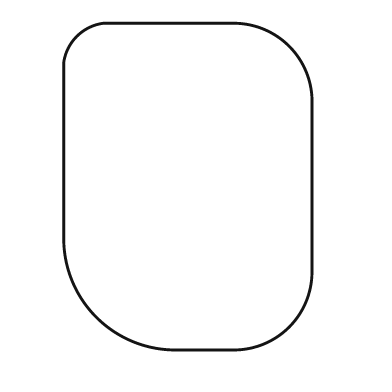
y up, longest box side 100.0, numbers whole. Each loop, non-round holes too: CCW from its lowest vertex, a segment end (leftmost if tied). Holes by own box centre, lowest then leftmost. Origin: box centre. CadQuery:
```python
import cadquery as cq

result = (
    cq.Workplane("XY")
    .moveTo(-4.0, -50.0)
    .lineTo(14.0, -50.0)
    .threePointArc((31.0, -43.0), (38.0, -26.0))
    .lineTo(38.0, 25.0)
    .threePointArc((31.0, 43.0), (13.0, 50.0))
    .lineTo(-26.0, 50.0)
    .threePointArc((-34.0, 46.0), (-38.0, 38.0))
    .lineTo(-38.0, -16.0)
    .threePointArc((-28.0, -40.0), (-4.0, -50.0))
    .close()
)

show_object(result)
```